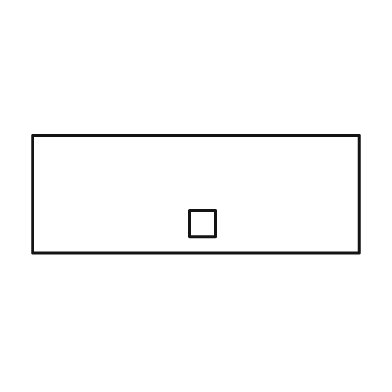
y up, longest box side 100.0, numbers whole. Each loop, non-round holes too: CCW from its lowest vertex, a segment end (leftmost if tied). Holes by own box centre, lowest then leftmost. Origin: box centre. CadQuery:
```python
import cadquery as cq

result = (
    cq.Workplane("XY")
    .moveTo(-50.0, -18.0)
    .lineTo(50.0, -18.0)
    .lineTo(50.0, 18.0)
    .lineTo(-50.0, 18.0)
    .close()
    .moveTo(-2.0, -13.0)
    .lineTo(6.0, -13.0)
    .lineTo(6.0, -5.0)
    .lineTo(-2.0, -5.0)
    .close()
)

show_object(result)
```